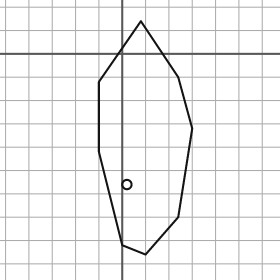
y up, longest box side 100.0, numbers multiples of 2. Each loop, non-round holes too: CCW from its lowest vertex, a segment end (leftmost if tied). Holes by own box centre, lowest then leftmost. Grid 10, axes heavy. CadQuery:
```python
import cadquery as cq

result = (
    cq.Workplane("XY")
    .moveTo(10.0, -86.0)
    .lineTo(24.0, -70.0)
    .lineTo(30.0, -32.0)
    .lineTo(24.0, -10.0)
    .lineTo(8.0, 14.0)
    .lineTo(-10.0, -12.0)
    .lineTo(-10.0, -42.0)
    .lineTo(0.0, -82.0)
    .close()
    .moveTo(2.0, -56.0)
    .circle(2.0)
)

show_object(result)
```